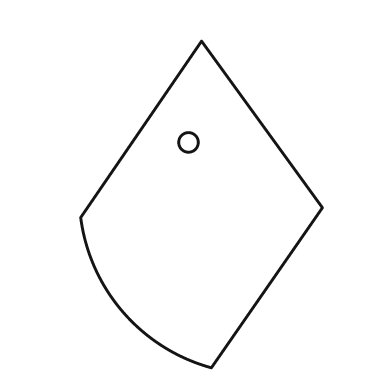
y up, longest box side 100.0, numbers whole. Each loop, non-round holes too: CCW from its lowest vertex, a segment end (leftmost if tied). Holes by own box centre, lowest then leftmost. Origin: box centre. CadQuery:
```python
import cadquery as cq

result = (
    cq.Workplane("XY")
    .moveTo(3.0, -50.0)
    .lineTo(37.0, -1.0)
    .lineTo(0.0, 50.0)
    .lineTo(-37.0, -4.0)
    .threePointArc((-24.0, -33.0), (3.0, -50.0))
    .close()
    .moveTo(-4.0, 19.0)
    .circle(3.0)
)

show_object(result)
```